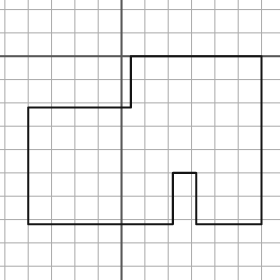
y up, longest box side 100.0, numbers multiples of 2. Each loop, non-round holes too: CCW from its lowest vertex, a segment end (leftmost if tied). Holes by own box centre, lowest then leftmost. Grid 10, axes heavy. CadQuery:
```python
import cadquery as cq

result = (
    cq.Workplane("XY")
    .moveTo(-40.0, -72.0)
    .lineTo(22.0, -72.0)
    .lineTo(22.0, -50.0)
    .lineTo(32.0, -50.0)
    .lineTo(32.0, -72.0)
    .lineTo(60.0, -72.0)
    .lineTo(60.0, 0.0)
    .lineTo(4.0, 0.0)
    .lineTo(4.0, -22.0)
    .lineTo(-40.0, -22.0)
    .close()
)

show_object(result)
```